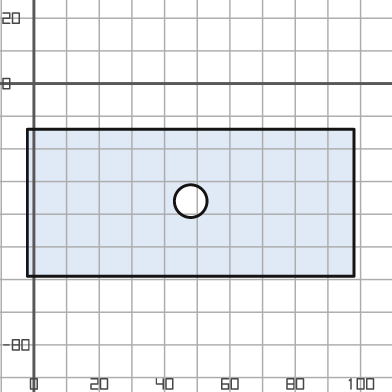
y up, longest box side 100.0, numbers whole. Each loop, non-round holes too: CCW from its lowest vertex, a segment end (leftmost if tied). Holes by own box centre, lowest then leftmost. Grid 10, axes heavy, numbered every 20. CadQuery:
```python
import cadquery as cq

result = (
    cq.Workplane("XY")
    .moveTo(-2.0, -59.0)
    .lineTo(98.0, -59.0)
    .lineTo(98.0, -14.0)
    .lineTo(-2.0, -14.0)
    .close()
    .moveTo(48.0, -36.0)
    .circle(5.0)
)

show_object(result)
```